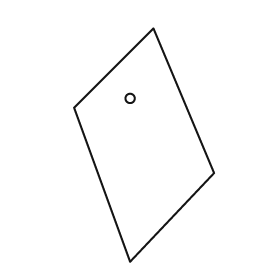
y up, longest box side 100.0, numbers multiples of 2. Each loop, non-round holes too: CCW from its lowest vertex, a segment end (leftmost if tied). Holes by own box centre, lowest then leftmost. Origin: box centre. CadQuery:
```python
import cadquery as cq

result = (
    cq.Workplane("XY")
    .moveTo(-6.0, -50.0)
    .lineTo(30.0, -12.0)
    .lineTo(4.0, 50.0)
    .lineTo(-30.0, 16.0)
    .close()
    .moveTo(-6.0, 20.0)
    .circle(2.0)
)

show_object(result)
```